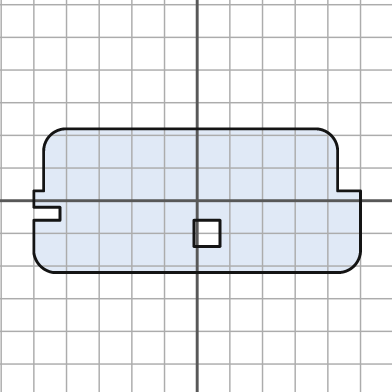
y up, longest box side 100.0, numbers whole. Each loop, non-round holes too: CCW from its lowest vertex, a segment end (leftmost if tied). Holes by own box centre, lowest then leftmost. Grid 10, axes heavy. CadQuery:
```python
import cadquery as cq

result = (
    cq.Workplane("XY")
    .moveTo(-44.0, -22.0)
    .lineTo(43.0, -22.0)
    .threePointArc((48.0, -20.0), (50.0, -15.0))
    .lineTo(50.0, 3.0)
    .lineTo(43.0, 3.0)
    .lineTo(43.0, 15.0)
    .threePointArc((41.0, 20.0), (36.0, 22.0))
    .lineTo(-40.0, 22.0)
    .threePointArc((-45.0, 20.0), (-47.0, 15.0))
    .lineTo(-47.0, 3.0)
    .lineTo(-50.0, 3.0)
    .lineTo(-50.0, -2.0)
    .lineTo(-42.0, -2.0)
    .lineTo(-42.0, -6.0)
    .lineTo(-50.0, -6.0)
    .lineTo(-50.0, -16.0)
    .threePointArc((-48.0, -20.0), (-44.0, -22.0))
    .close()
    .moveTo(-1.0, -14.0)
    .lineTo(7.0, -14.0)
    .lineTo(7.0, -6.0)
    .lineTo(-1.0, -6.0)
    .close()
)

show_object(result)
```